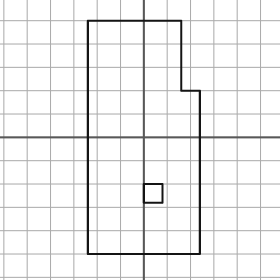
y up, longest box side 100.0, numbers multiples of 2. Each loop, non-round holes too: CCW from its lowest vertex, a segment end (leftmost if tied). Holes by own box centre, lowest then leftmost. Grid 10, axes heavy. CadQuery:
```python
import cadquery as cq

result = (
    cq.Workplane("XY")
    .moveTo(-24.0, -50.0)
    .lineTo(24.0, -50.0)
    .lineTo(24.0, 20.0)
    .lineTo(16.0, 20.0)
    .lineTo(16.0, 50.0)
    .lineTo(-24.0, 50.0)
    .close()
    .moveTo(0.0, -28.0)
    .lineTo(8.0, -28.0)
    .lineTo(8.0, -20.0)
    .lineTo(0.0, -20.0)
    .close()
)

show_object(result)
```